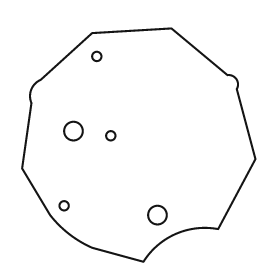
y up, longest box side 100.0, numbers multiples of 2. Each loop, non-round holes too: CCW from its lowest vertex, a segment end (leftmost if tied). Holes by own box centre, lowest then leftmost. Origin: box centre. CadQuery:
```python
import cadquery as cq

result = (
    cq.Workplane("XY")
    .moveTo(2.0, -50.0)
    .threePointArc((16.0, -38.0), (34.0, -36.0))
    .lineTo(50.0, -6.0)
    .lineTo(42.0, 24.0)
    .threePointArc((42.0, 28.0), (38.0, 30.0))
    .lineTo(14.0, 50.0)
    .lineTo(-20.0, 48.0)
    .lineTo(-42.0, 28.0)
    .threePointArc((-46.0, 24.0), (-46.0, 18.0))
    .lineTo(-50.0, -10.0)
    .lineTo(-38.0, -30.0)
    .threePointArc((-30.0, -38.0), (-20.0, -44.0))
    .close()
    .moveTo(8.0, -30.0)
    .circle(4.0)
    .moveTo(-32.0, -26.0)
    .circle(2.0)
    .moveTo(-12.0, 4.0)
    .circle(2.0)
    .moveTo(-28.0, 6.0)
    .circle(4.0)
    .moveTo(-18.0, 38.0)
    .circle(2.0)
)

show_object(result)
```